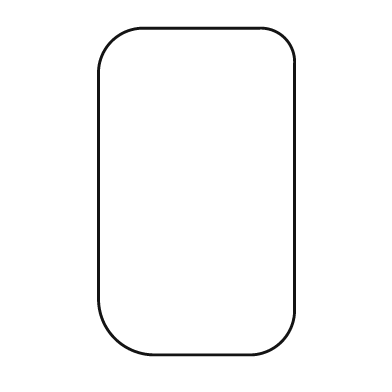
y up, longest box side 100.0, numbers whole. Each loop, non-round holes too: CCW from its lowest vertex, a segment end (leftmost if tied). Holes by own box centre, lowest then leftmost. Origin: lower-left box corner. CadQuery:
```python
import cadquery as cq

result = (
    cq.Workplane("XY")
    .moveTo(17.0, 0.0)
    .lineTo(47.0, 0.0)
    .threePointArc((56.0, 4.0), (60.0, 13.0))
    .lineTo(60.0, 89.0)
    .threePointArc((57.0, 97.0), (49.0, 100.0))
    .lineTo(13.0, 100.0)
    .threePointArc((4.0, 96.0), (0.0, 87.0))
    .lineTo(0.0, 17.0)
    .threePointArc((5.0, 5.0), (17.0, 0.0))
    .close()
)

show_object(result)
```